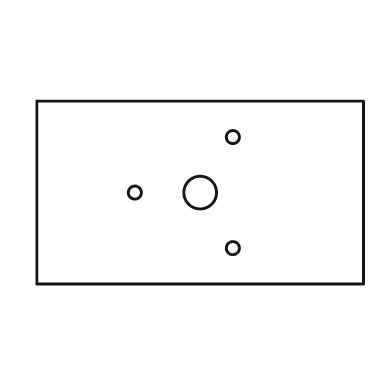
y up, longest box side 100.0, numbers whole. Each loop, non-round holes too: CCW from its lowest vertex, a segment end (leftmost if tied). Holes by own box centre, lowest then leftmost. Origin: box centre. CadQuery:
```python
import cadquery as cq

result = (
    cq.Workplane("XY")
    .moveTo(-50.0, -28.0)
    .lineTo(50.0, -28.0)
    .lineTo(50.0, 28.0)
    .lineTo(-50.0, 28.0)
    .close()
    .moveTo(10.0, -17.0)
    .circle(2.0)
    .moveTo(-20.0, 0.0)
    .circle(2.0)
    .moveTo(0.0, 0.0)
    .circle(5.0)
    .moveTo(10.0, 17.0)
    .circle(2.0)
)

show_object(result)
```